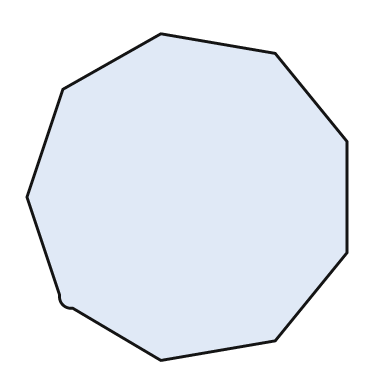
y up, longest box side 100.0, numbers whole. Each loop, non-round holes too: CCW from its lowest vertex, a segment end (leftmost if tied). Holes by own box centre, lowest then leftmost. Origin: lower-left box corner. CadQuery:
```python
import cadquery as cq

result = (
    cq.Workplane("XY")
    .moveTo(41.0, 0.0)
    .lineTo(76.0, 6.0)
    .lineTo(98.0, 33.0)
    .lineTo(98.0, 67.0)
    .lineTo(76.0, 94.0)
    .lineTo(41.0, 100.0)
    .lineTo(11.0, 83.0)
    .lineTo(0.0, 50.0)
    .lineTo(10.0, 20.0)
    .threePointArc((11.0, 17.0), (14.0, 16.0))
    .close()
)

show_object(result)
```